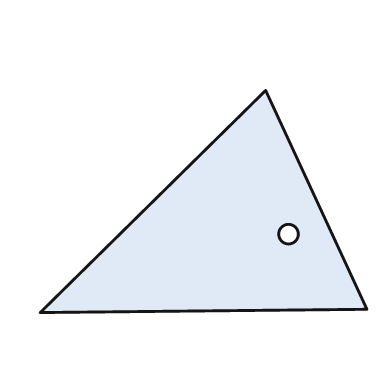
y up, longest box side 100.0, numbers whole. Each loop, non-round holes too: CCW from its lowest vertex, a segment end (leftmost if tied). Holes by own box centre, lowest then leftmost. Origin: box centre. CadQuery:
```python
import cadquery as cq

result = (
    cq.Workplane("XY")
    .moveTo(-50.0, -34.0)
    .lineTo(50.0, -33.0)
    .lineTo(19.0, 34.0)
    .close()
    .moveTo(26.0, -10.0)
    .circle(3.0)
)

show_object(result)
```